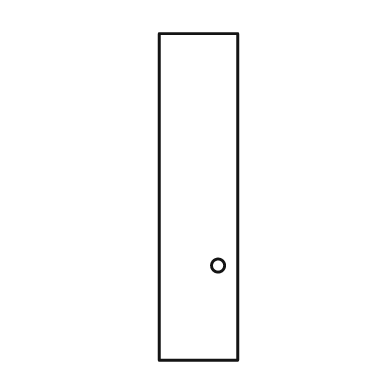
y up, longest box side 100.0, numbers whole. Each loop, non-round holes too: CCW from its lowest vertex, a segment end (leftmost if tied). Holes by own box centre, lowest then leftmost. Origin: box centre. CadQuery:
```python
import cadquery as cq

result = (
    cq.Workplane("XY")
    .moveTo(-12.0, -50.0)
    .lineTo(12.0, -50.0)
    .lineTo(12.0, 50.0)
    .lineTo(-12.0, 50.0)
    .close()
    .moveTo(6.0, -21.0)
    .circle(2.0)
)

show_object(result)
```